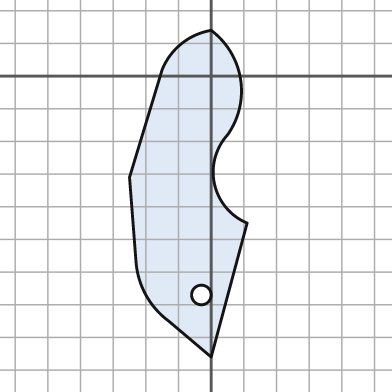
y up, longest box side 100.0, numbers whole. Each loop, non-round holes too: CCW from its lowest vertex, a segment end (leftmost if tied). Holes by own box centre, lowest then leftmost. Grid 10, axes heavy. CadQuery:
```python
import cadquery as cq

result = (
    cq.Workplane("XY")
    .moveTo(0.0, -86.0)
    .lineTo(11.0, -45.0)
    .threePointArc((1.0, -33.0), (5.0, -18.0))
    .threePointArc((9.0, -1.0), (0.0, 14.0))
    .threePointArc((-9.0, 10.0), (-15.0, 2.0))
    .lineTo(-25.0, -31.0)
    .lineTo(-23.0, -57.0)
    .threePointArc((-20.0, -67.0), (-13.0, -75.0))
    .close()
    .moveTo(-3.0, -67.0)
    .circle(3.0)
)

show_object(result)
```